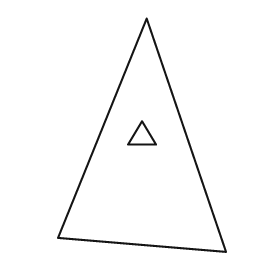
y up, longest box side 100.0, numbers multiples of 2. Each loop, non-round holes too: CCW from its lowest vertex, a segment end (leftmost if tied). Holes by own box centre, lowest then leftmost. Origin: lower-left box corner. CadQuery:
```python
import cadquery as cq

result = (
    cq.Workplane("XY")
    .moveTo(72.0, 0.0)
    .lineTo(38.0, 100.0)
    .lineTo(0.0, 6.0)
    .close()
    .moveTo(30.0, 46.0)
    .lineTo(42.0, 46.0)
    .lineTo(36.0, 56.0)
    .close()
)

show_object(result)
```